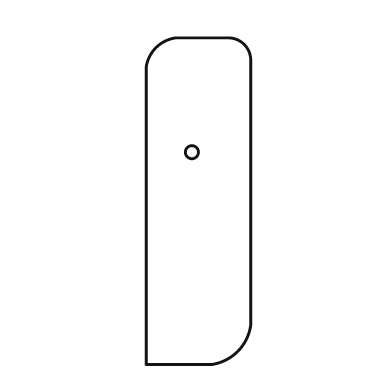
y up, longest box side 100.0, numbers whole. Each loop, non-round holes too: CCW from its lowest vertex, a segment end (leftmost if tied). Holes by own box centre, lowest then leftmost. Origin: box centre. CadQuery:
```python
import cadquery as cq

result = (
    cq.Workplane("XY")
    .moveTo(-16.0, -50.0)
    .lineTo(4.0, -50.0)
    .threePointArc((12.0, -46.0), (16.0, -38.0))
    .lineTo(16.0, 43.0)
    .threePointArc((14.0, 48.0), (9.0, 50.0))
    .lineTo(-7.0, 50.0)
    .threePointArc((-13.0, 47.0), (-16.0, 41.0))
    .close()
    .moveTo(-2.0, 15.0)
    .circle(2.0)
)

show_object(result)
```